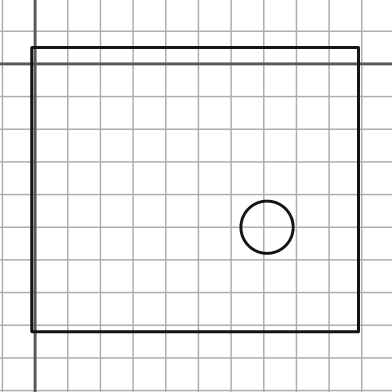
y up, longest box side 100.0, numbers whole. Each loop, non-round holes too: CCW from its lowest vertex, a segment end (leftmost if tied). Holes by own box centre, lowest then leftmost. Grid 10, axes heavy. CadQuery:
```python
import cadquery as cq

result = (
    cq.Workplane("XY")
    .moveTo(-1.0, -82.0)
    .lineTo(99.0, -82.0)
    .lineTo(99.0, 5.0)
    .lineTo(-1.0, 5.0)
    .close()
    .moveTo(71.0, -50.0)
    .circle(8.0)
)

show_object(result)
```